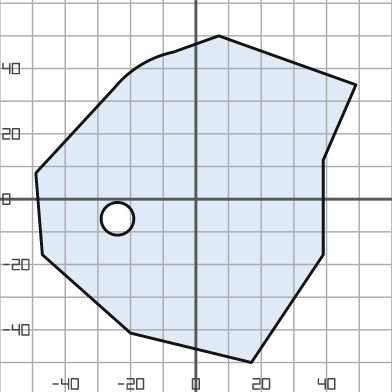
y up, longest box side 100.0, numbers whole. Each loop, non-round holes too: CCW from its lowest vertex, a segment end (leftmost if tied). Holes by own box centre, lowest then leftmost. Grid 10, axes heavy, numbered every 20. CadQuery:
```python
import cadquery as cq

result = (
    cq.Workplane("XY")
    .moveTo(17.0, -50.0)
    .lineTo(39.0, -17.0)
    .lineTo(39.0, 12.0)
    .lineTo(49.0, 35.0)
    .lineTo(7.0, 50.0)
    .lineTo(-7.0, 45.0)
    .threePointArc((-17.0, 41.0), (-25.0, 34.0))
    .lineTo(-49.0, 8.0)
    .lineTo(-47.0, -17.0)
    .lineTo(-20.0, -41.0)
    .close()
    .moveTo(-24.0, -6.0)
    .circle(5.0)
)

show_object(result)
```